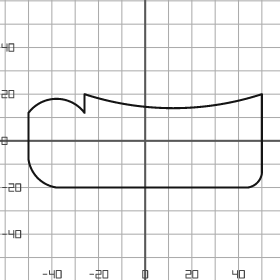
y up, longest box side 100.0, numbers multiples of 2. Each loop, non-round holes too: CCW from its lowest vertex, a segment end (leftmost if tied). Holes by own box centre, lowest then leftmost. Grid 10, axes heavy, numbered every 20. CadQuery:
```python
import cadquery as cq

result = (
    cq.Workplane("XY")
    .moveTo(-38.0, -20.0)
    .lineTo(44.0, -20.0)
    .threePointArc((48.0, -18.0), (50.0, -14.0))
    .lineTo(50.0, 20.0)
    .threePointArc((12.0, 14.0), (-26.0, 20.0))
    .lineTo(-26.0, 12.0)
    .threePointArc((-38.0, 18.0), (-50.0, 12.0))
    .lineTo(-50.0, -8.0)
    .threePointArc((-46.0, -16.0), (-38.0, -20.0))
    .close()
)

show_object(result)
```